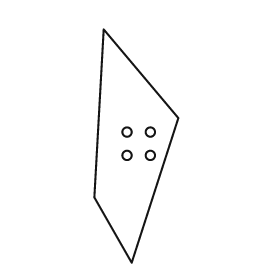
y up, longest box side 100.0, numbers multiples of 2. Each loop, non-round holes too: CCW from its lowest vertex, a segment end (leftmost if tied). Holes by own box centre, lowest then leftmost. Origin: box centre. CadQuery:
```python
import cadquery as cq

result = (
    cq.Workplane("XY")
    .moveTo(-2.0, -50.0)
    .lineTo(18.0, 12.0)
    .lineTo(-14.0, 50.0)
    .lineTo(-18.0, -22.0)
    .close()
    .moveTo(-4.0, -4.0)
    .circle(2.0)
    .moveTo(6.0, -4.0)
    .circle(2.0)
    .moveTo(-4.0, 6.0)
    .circle(2.0)
    .moveTo(6.0, 6.0)
    .circle(2.0)
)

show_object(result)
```